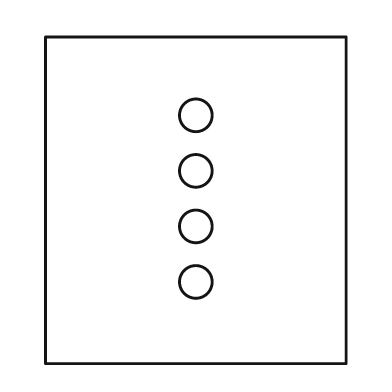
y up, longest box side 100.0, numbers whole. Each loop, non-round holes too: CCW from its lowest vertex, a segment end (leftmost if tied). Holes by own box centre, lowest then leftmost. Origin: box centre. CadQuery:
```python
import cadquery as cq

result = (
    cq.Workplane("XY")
    .moveTo(-46.0, -50.0)
    .lineTo(46.0, -50.0)
    .lineTo(46.0, 50.0)
    .lineTo(-46.0, 50.0)
    .close()
    .moveTo(0.0, -25.0)
    .circle(5.0)
    .moveTo(0.0, -8.0)
    .circle(5.0)
    .moveTo(0.0, 9.0)
    .circle(5.0)
    .moveTo(0.0, 26.0)
    .circle(5.0)
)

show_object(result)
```